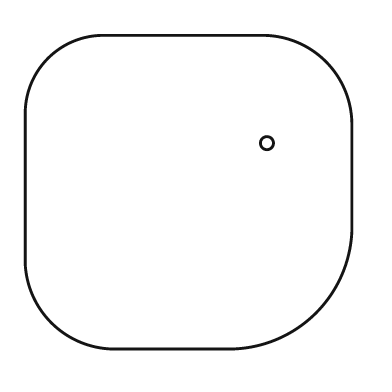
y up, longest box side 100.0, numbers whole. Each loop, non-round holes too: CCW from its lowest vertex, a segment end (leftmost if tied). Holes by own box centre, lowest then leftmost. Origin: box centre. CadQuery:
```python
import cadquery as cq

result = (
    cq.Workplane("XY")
    .moveTo(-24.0, -48.0)
    .lineTo(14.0, -48.0)
    .threePointArc((39.0, -37.0), (50.0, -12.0))
    .lineTo(50.0, 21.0)
    .threePointArc((42.0, 40.0), (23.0, 48.0))
    .lineTo(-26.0, 48.0)
    .threePointArc((-43.0, 41.0), (-50.0, 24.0))
    .lineTo(-50.0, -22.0)
    .threePointArc((-42.0, -40.0), (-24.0, -48.0))
    .close()
    .moveTo(24.0, 15.0)
    .circle(2.0)
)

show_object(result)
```